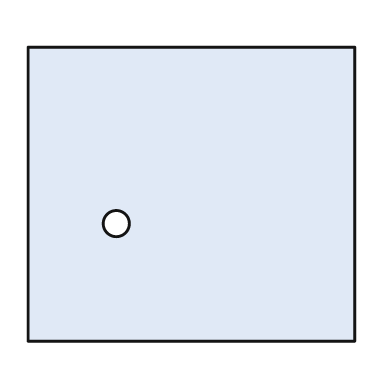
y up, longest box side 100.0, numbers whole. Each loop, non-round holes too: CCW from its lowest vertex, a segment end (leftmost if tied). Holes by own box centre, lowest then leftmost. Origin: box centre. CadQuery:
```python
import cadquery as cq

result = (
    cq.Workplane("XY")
    .moveTo(-50.0, -45.0)
    .lineTo(50.0, -45.0)
    .lineTo(50.0, 45.0)
    .lineTo(-50.0, 45.0)
    .close()
    .moveTo(-23.0, -9.0)
    .circle(4.0)
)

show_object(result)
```